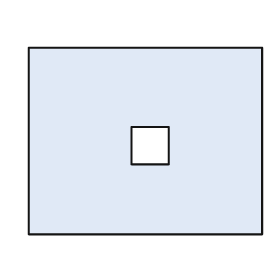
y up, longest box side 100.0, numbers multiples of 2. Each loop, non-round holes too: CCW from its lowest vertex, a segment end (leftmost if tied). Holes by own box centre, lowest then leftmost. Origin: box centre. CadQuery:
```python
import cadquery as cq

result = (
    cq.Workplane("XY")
    .moveTo(-50.0, -40.0)
    .lineTo(50.0, -40.0)
    .lineTo(50.0, 40.0)
    .lineTo(-50.0, 40.0)
    .close()
    .moveTo(-6.0, -10.0)
    .lineTo(10.0, -10.0)
    .lineTo(10.0, 6.0)
    .lineTo(-6.0, 6.0)
    .close()
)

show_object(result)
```